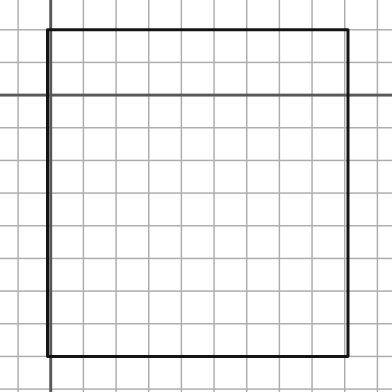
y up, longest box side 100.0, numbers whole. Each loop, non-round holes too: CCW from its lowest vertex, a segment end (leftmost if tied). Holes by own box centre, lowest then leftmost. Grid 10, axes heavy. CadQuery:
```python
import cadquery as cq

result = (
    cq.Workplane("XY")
    .moveTo(-1.0, -80.0)
    .lineTo(91.0, -80.0)
    .lineTo(91.0, 20.0)
    .lineTo(-1.0, 20.0)
    .close()
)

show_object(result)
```